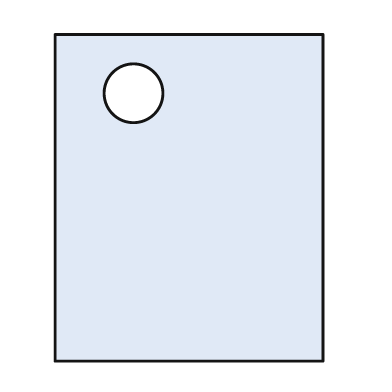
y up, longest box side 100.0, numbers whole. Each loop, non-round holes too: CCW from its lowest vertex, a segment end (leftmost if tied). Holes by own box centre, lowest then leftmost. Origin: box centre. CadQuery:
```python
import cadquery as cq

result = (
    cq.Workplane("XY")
    .moveTo(-41.0, -50.0)
    .lineTo(41.0, -50.0)
    .lineTo(41.0, 50.0)
    .lineTo(-41.0, 50.0)
    .close()
    .moveTo(-17.0, 32.0)
    .circle(9.0)
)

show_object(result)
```